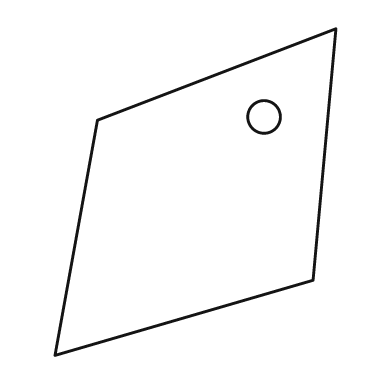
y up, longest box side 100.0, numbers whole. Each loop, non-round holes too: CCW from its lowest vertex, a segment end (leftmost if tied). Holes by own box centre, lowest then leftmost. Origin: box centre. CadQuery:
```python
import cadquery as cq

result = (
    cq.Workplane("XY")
    .moveTo(-43.0, -50.0)
    .lineTo(36.0, -27.0)
    .lineTo(43.0, 50.0)
    .lineTo(-30.0, 22.0)
    .close()
    .moveTo(21.0, 23.0)
    .circle(5.0)
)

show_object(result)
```